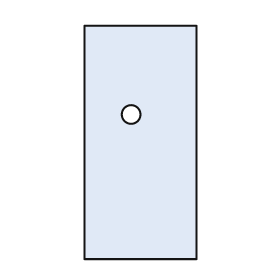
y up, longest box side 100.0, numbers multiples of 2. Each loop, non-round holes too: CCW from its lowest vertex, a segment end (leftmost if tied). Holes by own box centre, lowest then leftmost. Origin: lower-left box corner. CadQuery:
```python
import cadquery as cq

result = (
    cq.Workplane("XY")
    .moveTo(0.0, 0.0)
    .lineTo(48.0, 0.0)
    .lineTo(48.0, 100.0)
    .lineTo(0.0, 100.0)
    .close()
    .moveTo(20.0, 62.0)
    .circle(4.0)
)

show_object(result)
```